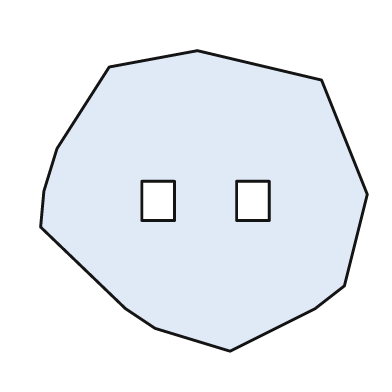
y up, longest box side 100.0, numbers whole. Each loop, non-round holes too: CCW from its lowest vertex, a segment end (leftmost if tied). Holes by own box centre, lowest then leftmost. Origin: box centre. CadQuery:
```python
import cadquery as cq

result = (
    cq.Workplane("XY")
    .moveTo(8.0, -46.0)
    .lineTo(34.0, -33.0)
    .lineTo(43.0, -26.0)
    .lineTo(50.0, 2.0)
    .lineTo(36.0, 37.0)
    .lineTo(-2.0, 46.0)
    .lineTo(-29.0, 41.0)
    .lineTo(-45.0, 16.0)
    .lineTo(-49.0, 3.0)
    .lineTo(-50.0, -8.0)
    .lineTo(-24.0, -33.0)
    .lineTo(-15.0, -39.0)
    .close()
    .moveTo(-19.0, -6.0)
    .lineTo(-9.0, -6.0)
    .lineTo(-9.0, 6.0)
    .lineTo(-19.0, 6.0)
    .close()
    .moveTo(10.0, -6.0)
    .lineTo(20.0, -6.0)
    .lineTo(20.0, 6.0)
    .lineTo(10.0, 6.0)
    .close()
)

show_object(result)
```